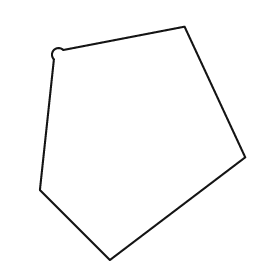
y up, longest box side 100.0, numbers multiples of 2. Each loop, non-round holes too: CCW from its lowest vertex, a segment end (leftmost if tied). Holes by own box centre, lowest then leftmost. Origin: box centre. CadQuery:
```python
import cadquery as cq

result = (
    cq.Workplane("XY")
    .moveTo(-14.0, -50.0)
    .lineTo(44.0, -6.0)
    .lineTo(18.0, 50.0)
    .lineTo(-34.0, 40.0)
    .threePointArc((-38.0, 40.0), (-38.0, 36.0))
    .lineTo(-44.0, -20.0)
    .close()
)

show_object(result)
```